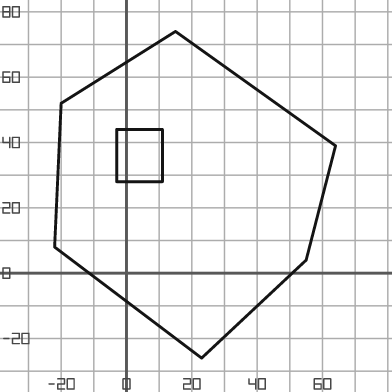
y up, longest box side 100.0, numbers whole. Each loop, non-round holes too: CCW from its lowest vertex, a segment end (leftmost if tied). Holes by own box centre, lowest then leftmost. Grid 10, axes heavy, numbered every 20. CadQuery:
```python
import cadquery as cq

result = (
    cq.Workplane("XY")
    .moveTo(23.0, -26.0)
    .lineTo(55.0, 4.0)
    .lineTo(64.0, 39.0)
    .lineTo(15.0, 74.0)
    .lineTo(-20.0, 52.0)
    .lineTo(-22.0, 8.0)
    .close()
    .moveTo(-3.0, 28.0)
    .lineTo(11.0, 28.0)
    .lineTo(11.0, 44.0)
    .lineTo(-3.0, 44.0)
    .close()
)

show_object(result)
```